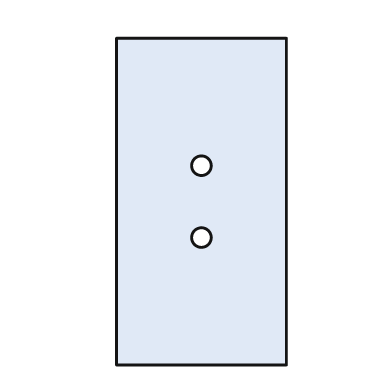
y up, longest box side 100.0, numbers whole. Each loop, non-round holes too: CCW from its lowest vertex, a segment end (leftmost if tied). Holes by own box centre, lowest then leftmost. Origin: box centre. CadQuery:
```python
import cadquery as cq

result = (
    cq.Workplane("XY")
    .moveTo(-26.0, -50.0)
    .lineTo(26.0, -50.0)
    .lineTo(26.0, 50.0)
    .lineTo(-26.0, 50.0)
    .close()
    .moveTo(0.0, -11.0)
    .circle(3.0)
    .moveTo(0.0, 11.0)
    .circle(3.0)
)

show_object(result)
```